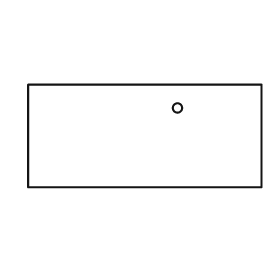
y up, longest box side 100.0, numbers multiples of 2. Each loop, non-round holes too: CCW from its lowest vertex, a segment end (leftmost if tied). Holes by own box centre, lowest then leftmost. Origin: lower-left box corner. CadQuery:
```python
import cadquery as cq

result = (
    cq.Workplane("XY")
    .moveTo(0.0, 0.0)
    .lineTo(100.0, 0.0)
    .lineTo(100.0, 44.0)
    .lineTo(0.0, 44.0)
    .close()
    .moveTo(64.0, 34.0)
    .circle(2.0)
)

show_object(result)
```